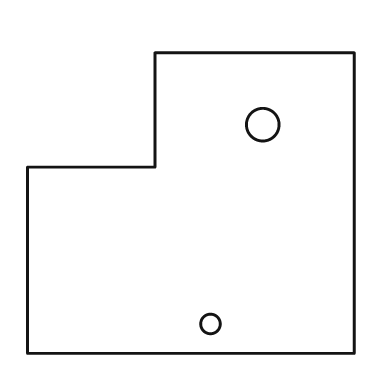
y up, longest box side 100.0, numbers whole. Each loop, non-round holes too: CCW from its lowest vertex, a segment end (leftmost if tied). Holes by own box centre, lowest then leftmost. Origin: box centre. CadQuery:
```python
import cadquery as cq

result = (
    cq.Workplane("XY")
    .moveTo(-50.0, -46.0)
    .lineTo(50.0, -46.0)
    .lineTo(50.0, 46.0)
    .lineTo(-11.0, 46.0)
    .lineTo(-11.0, 11.0)
    .lineTo(-50.0, 11.0)
    .close()
    .moveTo(6.0, -37.0)
    .circle(3.0)
    .moveTo(22.0, 24.0)
    .circle(5.0)
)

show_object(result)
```